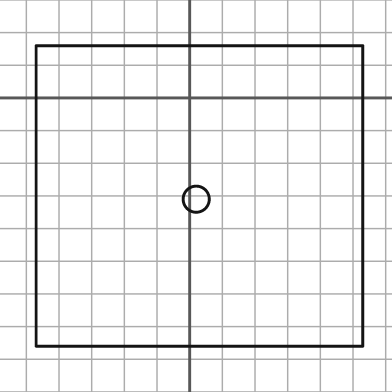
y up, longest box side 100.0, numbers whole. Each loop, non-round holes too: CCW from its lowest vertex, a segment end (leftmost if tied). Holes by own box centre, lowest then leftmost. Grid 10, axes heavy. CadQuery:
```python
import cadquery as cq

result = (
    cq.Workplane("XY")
    .moveTo(-47.0, -76.0)
    .lineTo(53.0, -76.0)
    .lineTo(53.0, 16.0)
    .lineTo(-47.0, 16.0)
    .close()
    .moveTo(2.0, -31.0)
    .circle(4.0)
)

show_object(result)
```